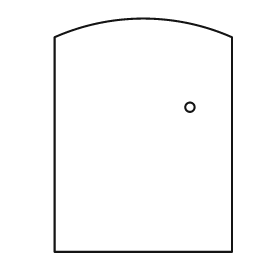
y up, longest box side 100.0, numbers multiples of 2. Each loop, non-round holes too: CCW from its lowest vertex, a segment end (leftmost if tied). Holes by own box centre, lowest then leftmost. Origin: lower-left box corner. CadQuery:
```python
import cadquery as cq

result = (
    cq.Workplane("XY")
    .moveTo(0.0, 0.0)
    .lineTo(76.0, 0.0)
    .lineTo(76.0, 92.0)
    .threePointArc((38.0, 100.0), (0.0, 92.0))
    .close()
    .moveTo(58.0, 62.0)
    .circle(2.0)
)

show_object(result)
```